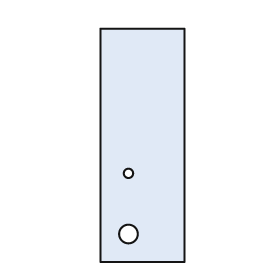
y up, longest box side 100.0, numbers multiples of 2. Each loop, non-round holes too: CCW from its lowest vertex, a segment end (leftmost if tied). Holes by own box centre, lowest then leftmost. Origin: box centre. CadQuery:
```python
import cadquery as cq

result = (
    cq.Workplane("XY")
    .moveTo(-18.0, -50.0)
    .lineTo(18.0, -50.0)
    .lineTo(18.0, 50.0)
    .lineTo(-18.0, 50.0)
    .close()
    .moveTo(-6.0, -38.0)
    .circle(4.0)
    .moveTo(-6.0, -12.0)
    .circle(2.0)
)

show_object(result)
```